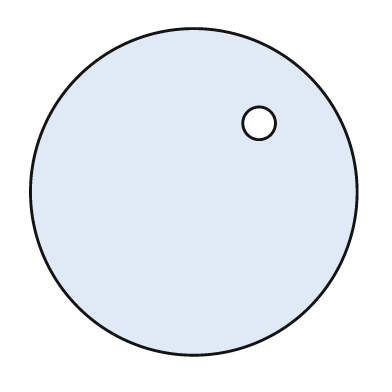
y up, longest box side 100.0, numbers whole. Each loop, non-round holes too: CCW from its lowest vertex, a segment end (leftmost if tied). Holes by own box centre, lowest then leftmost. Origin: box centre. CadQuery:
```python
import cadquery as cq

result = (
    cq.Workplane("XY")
    .moveTo(0.0, 0.0)
    .circle(50.0)
    .moveTo(20.0, 21.0)
    .circle(5.0)
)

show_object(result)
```